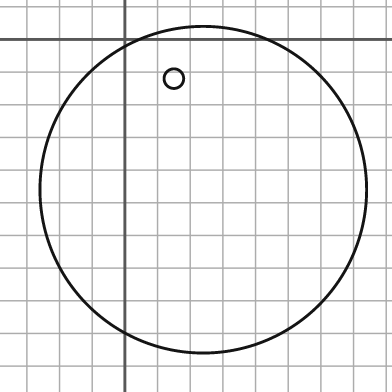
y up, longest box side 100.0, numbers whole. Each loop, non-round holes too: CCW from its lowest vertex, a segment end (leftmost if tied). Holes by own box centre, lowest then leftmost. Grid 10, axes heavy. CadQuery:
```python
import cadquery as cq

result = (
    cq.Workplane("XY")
    .moveTo(24.0, -46.0)
    .circle(50.0)
    .moveTo(15.0, -12.0)
    .circle(3.0)
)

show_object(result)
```